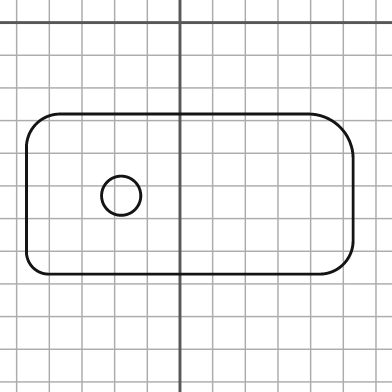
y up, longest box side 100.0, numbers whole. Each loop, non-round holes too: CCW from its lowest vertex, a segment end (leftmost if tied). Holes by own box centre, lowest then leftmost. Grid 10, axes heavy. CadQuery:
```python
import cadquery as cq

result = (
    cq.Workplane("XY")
    .moveTo(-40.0, -77.0)
    .lineTo(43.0, -77.0)
    .threePointArc((50.0, -74.0), (53.0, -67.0))
    .lineTo(53.0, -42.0)
    .threePointArc((49.0, -32.0), (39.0, -28.0))
    .lineTo(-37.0, -28.0)
    .threePointArc((-44.0, -31.0), (-47.0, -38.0))
    .lineTo(-47.0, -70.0)
    .threePointArc((-45.0, -75.0), (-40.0, -77.0))
    .close()
    .moveTo(-18.0, -53.0)
    .circle(6.0)
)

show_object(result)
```